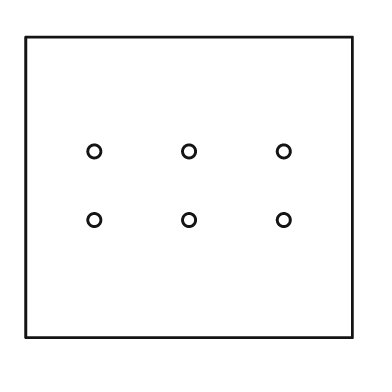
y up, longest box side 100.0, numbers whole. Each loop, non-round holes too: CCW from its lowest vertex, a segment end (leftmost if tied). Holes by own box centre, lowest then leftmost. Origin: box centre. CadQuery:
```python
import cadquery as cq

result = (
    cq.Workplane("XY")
    .moveTo(-50.0, -46.0)
    .lineTo(50.0, -46.0)
    .lineTo(50.0, 46.0)
    .lineTo(-50.0, 46.0)
    .close()
    .moveTo(-29.0, -10.0)
    .circle(2.0)
    .moveTo(0.0, -10.0)
    .circle(2.0)
    .moveTo(29.0, -10.0)
    .circle(2.0)
    .moveTo(-29.0, 11.0)
    .circle(2.0)
    .moveTo(0.0, 11.0)
    .circle(2.0)
    .moveTo(29.0, 11.0)
    .circle(2.0)
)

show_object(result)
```